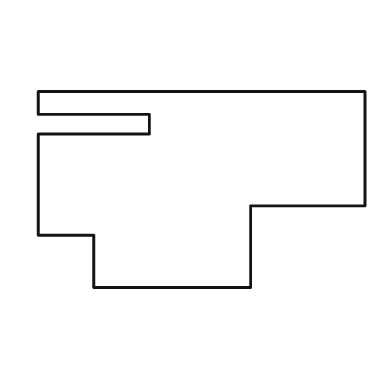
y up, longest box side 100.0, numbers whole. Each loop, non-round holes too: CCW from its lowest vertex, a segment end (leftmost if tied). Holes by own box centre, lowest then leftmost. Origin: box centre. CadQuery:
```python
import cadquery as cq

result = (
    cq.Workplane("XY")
    .moveTo(-33.0, -30.0)
    .lineTo(15.0, -30.0)
    .lineTo(15.0, -5.0)
    .lineTo(50.0, -5.0)
    .lineTo(50.0, 30.0)
    .lineTo(-50.0, 30.0)
    .lineTo(-50.0, 23.0)
    .lineTo(-16.0, 23.0)
    .lineTo(-16.0, 17.0)
    .lineTo(-50.0, 17.0)
    .lineTo(-50.0, -14.0)
    .lineTo(-33.0, -14.0)
    .close()
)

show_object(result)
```